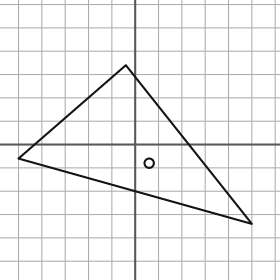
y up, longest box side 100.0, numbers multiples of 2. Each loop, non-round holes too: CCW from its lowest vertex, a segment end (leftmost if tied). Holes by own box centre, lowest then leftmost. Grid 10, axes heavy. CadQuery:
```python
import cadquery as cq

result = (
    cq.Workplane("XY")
    .moveTo(50.0, -34.0)
    .lineTo(-4.0, 34.0)
    .lineTo(-50.0, -6.0)
    .close()
    .moveTo(6.0, -8.0)
    .circle(2.0)
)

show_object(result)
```